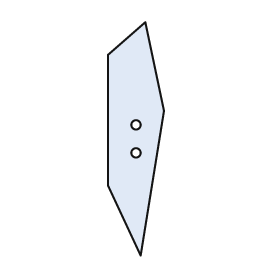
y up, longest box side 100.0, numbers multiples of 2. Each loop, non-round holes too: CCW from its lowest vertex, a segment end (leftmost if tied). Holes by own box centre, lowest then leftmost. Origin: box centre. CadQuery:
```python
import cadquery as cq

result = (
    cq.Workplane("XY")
    .moveTo(2.0, -50.0)
    .lineTo(12.0, 12.0)
    .lineTo(4.0, 50.0)
    .lineTo(-12.0, 36.0)
    .lineTo(-12.0, -20.0)
    .close()
    .moveTo(0.0, -6.0)
    .circle(2.0)
    .moveTo(0.0, 6.0)
    .circle(2.0)
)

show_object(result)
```